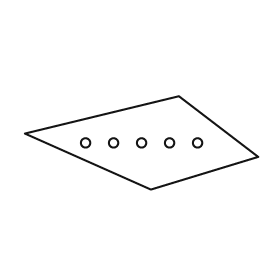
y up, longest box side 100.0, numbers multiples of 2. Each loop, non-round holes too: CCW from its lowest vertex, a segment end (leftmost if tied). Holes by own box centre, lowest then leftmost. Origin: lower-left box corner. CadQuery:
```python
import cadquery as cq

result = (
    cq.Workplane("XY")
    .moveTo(54.0, 0.0)
    .lineTo(100.0, 14.0)
    .lineTo(66.0, 40.0)
    .lineTo(0.0, 24.0)
    .close()
    .moveTo(26.0, 20.0)
    .circle(2.0)
    .moveTo(38.0, 20.0)
    .circle(2.0)
    .moveTo(50.0, 20.0)
    .circle(2.0)
    .moveTo(62.0, 20.0)
    .circle(2.0)
    .moveTo(74.0, 20.0)
    .circle(2.0)
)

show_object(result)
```